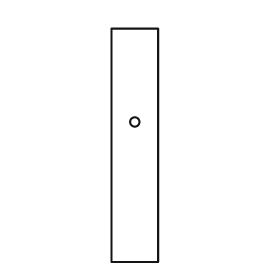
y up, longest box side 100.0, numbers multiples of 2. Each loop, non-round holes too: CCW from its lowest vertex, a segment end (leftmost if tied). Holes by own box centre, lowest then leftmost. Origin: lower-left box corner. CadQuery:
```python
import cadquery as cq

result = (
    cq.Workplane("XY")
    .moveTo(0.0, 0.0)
    .lineTo(20.0, 0.0)
    .lineTo(20.0, 100.0)
    .lineTo(0.0, 100.0)
    .close()
    .moveTo(10.0, 60.0)
    .circle(2.0)
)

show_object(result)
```